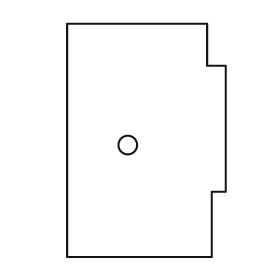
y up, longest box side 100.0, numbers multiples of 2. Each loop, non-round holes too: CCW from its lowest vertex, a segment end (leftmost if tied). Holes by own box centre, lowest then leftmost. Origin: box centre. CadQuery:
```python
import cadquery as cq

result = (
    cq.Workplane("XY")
    .moveTo(-34.0, -50.0)
    .lineTo(28.0, -50.0)
    .lineTo(28.0, -22.0)
    .lineTo(34.0, -22.0)
    .lineTo(34.0, 32.0)
    .lineTo(26.0, 32.0)
    .lineTo(26.0, 50.0)
    .lineTo(-34.0, 50.0)
    .close()
    .moveTo(-8.0, -2.0)
    .circle(4.0)
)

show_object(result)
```